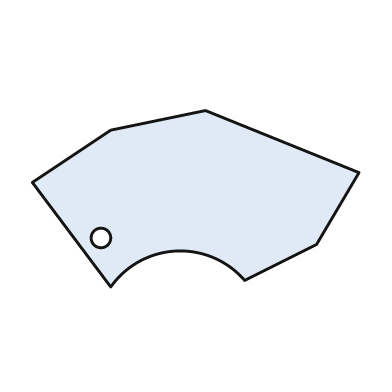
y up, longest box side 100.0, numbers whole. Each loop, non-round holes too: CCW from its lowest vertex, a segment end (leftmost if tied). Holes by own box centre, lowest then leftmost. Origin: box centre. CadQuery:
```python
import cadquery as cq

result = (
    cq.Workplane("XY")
    .moveTo(-26.0, -27.0)
    .threePointArc((-6.0, -16.0), (15.0, -25.0))
    .lineTo(37.0, -14.0)
    .lineTo(50.0, 8.0)
    .lineTo(3.0, 27.0)
    .lineTo(-26.0, 21.0)
    .lineTo(-50.0, 5.0)
    .close()
    .moveTo(-29.0, -12.0)
    .circle(3.0)
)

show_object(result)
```